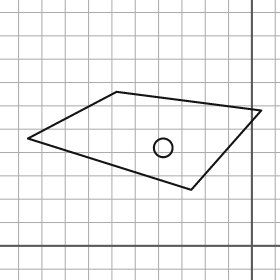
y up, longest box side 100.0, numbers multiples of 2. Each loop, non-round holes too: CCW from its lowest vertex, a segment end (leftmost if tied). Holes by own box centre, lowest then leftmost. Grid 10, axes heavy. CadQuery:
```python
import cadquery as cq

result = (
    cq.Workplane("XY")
    .moveTo(-26.0, 24.0)
    .lineTo(4.0, 58.0)
    .lineTo(-58.0, 66.0)
    .lineTo(-96.0, 46.0)
    .close()
    .moveTo(-38.0, 42.0)
    .circle(4.0)
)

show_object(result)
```